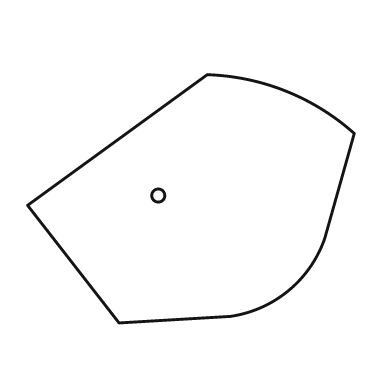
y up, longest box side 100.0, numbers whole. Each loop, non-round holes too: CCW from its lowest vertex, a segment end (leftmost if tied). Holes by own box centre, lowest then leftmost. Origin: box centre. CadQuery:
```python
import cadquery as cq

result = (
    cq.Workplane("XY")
    .moveTo(-22.0, -38.0)
    .lineTo(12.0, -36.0)
    .threePointArc((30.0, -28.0), (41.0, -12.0))
    .lineTo(50.0, 20.0)
    .threePointArc((29.0, 33.0), (5.0, 38.0))
    .lineTo(-50.0, -2.0)
    .close()
    .moveTo(-10.0, 1.0)
    .circle(2.0)
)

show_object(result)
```